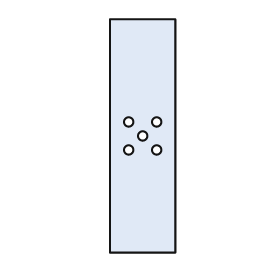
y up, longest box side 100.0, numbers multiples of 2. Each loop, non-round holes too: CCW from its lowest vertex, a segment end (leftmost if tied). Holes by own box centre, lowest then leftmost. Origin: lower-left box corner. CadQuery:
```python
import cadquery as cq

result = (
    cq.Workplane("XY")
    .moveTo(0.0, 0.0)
    .lineTo(28.0, 0.0)
    .lineTo(28.0, 100.0)
    .lineTo(0.0, 100.0)
    .close()
    .moveTo(8.0, 44.0)
    .circle(2.0)
    .moveTo(20.0, 44.0)
    .circle(2.0)
    .moveTo(14.0, 50.0)
    .circle(2.0)
    .moveTo(8.0, 56.0)
    .circle(2.0)
    .moveTo(20.0, 56.0)
    .circle(2.0)
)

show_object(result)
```